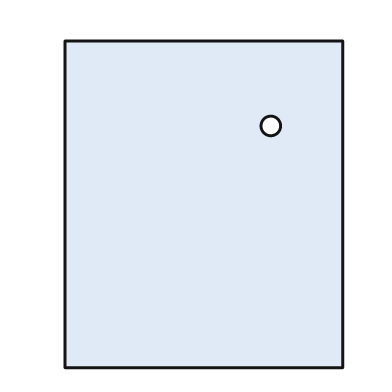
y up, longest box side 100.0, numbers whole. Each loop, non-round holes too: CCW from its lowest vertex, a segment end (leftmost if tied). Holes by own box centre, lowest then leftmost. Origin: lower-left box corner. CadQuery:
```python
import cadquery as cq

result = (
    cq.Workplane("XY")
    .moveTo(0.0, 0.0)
    .lineTo(85.0, 0.0)
    .lineTo(85.0, 100.0)
    .lineTo(0.0, 100.0)
    .close()
    .moveTo(63.0, 74.0)
    .circle(3.0)
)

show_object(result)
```